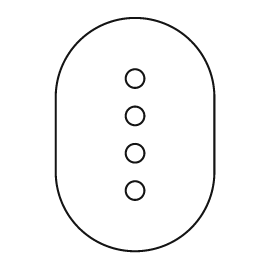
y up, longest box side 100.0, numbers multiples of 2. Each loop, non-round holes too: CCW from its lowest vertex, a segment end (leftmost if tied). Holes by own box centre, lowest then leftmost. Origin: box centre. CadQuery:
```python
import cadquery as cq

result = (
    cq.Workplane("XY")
    .moveTo(-34.0, -16.0)
    .threePointArc((0.0, -50.0), (34.0, -16.0))
    .lineTo(34.0, 16.0)
    .threePointArc((0.0, 50.0), (-34.0, 16.0))
    .close()
    .moveTo(0.0, -24.0)
    .circle(4.0)
    .moveTo(0.0, -8.0)
    .circle(4.0)
    .moveTo(0.0, 8.0)
    .circle(4.0)
    .moveTo(0.0, 24.0)
    .circle(4.0)
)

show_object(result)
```